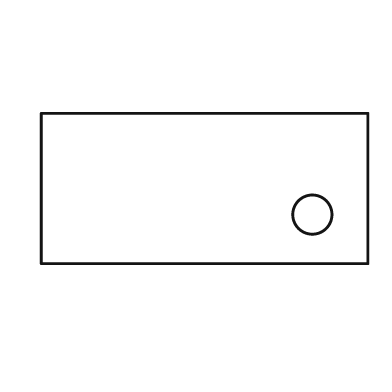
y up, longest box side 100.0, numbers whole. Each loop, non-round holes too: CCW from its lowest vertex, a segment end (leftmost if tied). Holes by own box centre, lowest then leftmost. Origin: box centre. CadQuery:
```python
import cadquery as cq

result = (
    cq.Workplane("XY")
    .moveTo(-50.0, -23.0)
    .lineTo(50.0, -23.0)
    .lineTo(50.0, 23.0)
    .lineTo(-50.0, 23.0)
    .close()
    .moveTo(33.0, -8.0)
    .circle(6.0)
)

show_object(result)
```